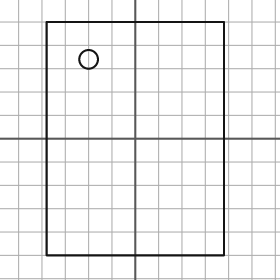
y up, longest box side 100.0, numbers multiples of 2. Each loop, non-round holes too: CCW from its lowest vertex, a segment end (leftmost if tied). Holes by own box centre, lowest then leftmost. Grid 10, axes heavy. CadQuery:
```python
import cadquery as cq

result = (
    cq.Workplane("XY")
    .moveTo(-38.0, -50.0)
    .lineTo(38.0, -50.0)
    .lineTo(38.0, 50.0)
    .lineTo(-38.0, 50.0)
    .close()
    .moveTo(-20.0, 34.0)
    .circle(4.0)
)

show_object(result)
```